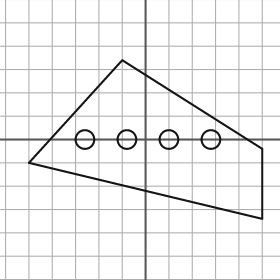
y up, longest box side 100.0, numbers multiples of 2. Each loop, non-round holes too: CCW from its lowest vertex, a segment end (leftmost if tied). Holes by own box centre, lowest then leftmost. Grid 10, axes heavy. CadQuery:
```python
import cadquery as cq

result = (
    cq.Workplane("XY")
    .moveTo(50.0, -34.0)
    .lineTo(50.0, -4.0)
    .lineTo(-10.0, 34.0)
    .lineTo(-50.0, -10.0)
    .close()
    .moveTo(-26.0, 0.0)
    .circle(4.0)
    .moveTo(-8.0, 0.0)
    .circle(4.0)
    .moveTo(10.0, 0.0)
    .circle(4.0)
    .moveTo(28.0, 0.0)
    .circle(4.0)
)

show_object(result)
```